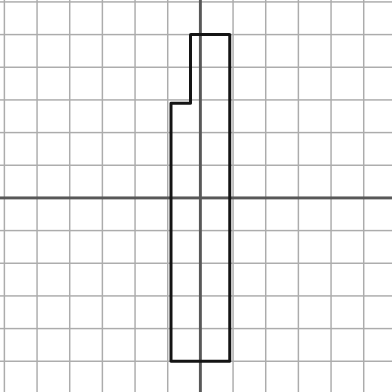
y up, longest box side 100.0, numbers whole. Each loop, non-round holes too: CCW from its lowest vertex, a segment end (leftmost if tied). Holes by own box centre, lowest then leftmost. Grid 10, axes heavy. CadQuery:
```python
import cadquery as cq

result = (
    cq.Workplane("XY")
    .moveTo(-9.0, -50.0)
    .lineTo(9.0, -50.0)
    .lineTo(9.0, 50.0)
    .lineTo(-3.0, 50.0)
    .lineTo(-3.0, 29.0)
    .lineTo(-9.0, 29.0)
    .close()
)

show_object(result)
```